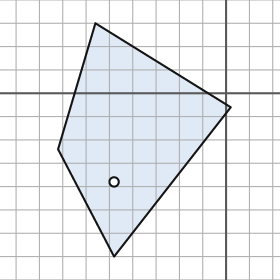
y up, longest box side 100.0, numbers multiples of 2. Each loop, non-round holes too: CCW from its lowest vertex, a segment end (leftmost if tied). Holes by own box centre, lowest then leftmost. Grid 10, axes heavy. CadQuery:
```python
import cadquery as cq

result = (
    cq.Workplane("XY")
    .moveTo(-48.0, -70.0)
    .lineTo(2.0, -6.0)
    .lineTo(-56.0, 30.0)
    .lineTo(-72.0, -24.0)
    .close()
    .moveTo(-48.0, -38.0)
    .circle(2.0)
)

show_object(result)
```